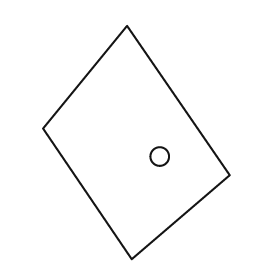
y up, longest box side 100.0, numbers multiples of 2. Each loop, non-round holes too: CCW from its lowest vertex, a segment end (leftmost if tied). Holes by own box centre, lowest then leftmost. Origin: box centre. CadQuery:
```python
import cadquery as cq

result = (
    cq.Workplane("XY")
    .moveTo(-2.0, -50.0)
    .lineTo(40.0, -14.0)
    .lineTo(-4.0, 50.0)
    .lineTo(-40.0, 6.0)
    .close()
    .moveTo(10.0, -6.0)
    .circle(4.0)
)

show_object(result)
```